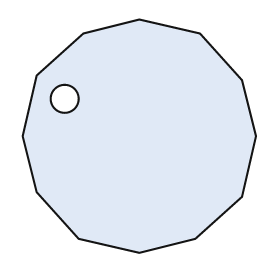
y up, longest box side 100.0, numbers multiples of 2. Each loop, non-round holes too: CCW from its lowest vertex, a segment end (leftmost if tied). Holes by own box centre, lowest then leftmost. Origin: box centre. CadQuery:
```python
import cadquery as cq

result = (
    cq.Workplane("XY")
    .moveTo(0.0, -50.0)
    .lineTo(24.0, -44.0)
    .lineTo(44.0, -26.0)
    .lineTo(50.0, 0.0)
    .lineTo(44.0, 24.0)
    .lineTo(26.0, 44.0)
    .lineTo(0.0, 50.0)
    .lineTo(-24.0, 44.0)
    .lineTo(-44.0, 26.0)
    .lineTo(-50.0, 0.0)
    .lineTo(-44.0, -24.0)
    .lineTo(-26.0, -44.0)
    .close()
    .moveTo(-32.0, 16.0)
    .circle(6.0)
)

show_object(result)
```